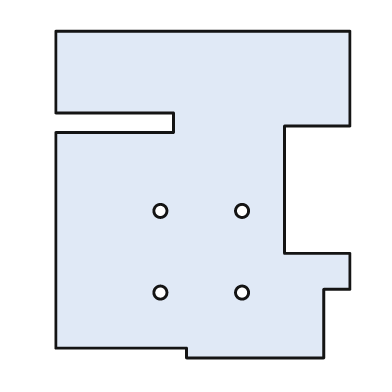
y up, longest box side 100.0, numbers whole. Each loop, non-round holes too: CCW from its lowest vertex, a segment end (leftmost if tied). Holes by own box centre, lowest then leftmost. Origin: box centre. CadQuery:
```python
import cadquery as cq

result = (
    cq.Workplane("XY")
    .moveTo(-5.0, -50.0)
    .lineTo(37.0, -50.0)
    .lineTo(37.0, -29.0)
    .lineTo(45.0, -29.0)
    .lineTo(45.0, -18.0)
    .lineTo(25.0, -18.0)
    .lineTo(25.0, 21.0)
    .lineTo(45.0, 21.0)
    .lineTo(45.0, 50.0)
    .lineTo(-45.0, 50.0)
    .lineTo(-45.0, 25.0)
    .lineTo(-9.0, 25.0)
    .lineTo(-9.0, 19.0)
    .lineTo(-45.0, 19.0)
    .lineTo(-45.0, -47.0)
    .lineTo(-5.0, -47.0)
    .close()
    .moveTo(-13.0, -30.0)
    .circle(2.0)
    .moveTo(12.0, -30.0)
    .circle(2.0)
    .moveTo(-13.0, -5.0)
    .circle(2.0)
    .moveTo(12.0, -5.0)
    .circle(2.0)
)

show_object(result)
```